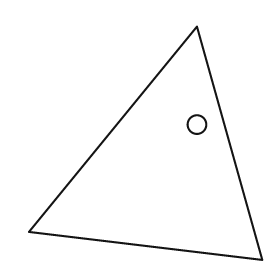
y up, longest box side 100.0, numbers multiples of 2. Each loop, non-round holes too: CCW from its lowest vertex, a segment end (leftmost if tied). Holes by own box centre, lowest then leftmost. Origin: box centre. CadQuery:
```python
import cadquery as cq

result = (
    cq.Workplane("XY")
    .moveTo(50.0, -50.0)
    .lineTo(22.0, 50.0)
    .lineTo(-50.0, -38.0)
    .close()
    .moveTo(22.0, 8.0)
    .circle(4.0)
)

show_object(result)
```